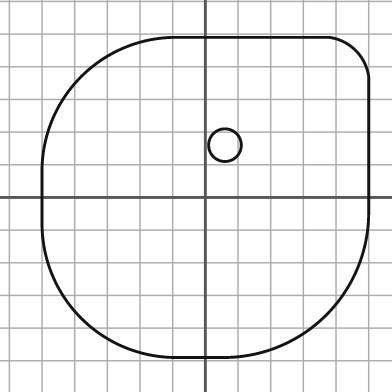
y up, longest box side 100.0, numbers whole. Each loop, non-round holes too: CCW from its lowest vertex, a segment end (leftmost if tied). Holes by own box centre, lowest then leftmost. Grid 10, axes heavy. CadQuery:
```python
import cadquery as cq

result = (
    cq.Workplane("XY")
    .moveTo(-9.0, -49.0)
    .lineTo(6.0, -49.0)
    .threePointArc((37.0, -36.0), (50.0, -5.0))
    .lineTo(50.0, 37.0)
    .threePointArc((46.0, 45.0), (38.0, 49.0))
    .lineTo(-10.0, 49.0)
    .threePointArc((-38.0, 37.0), (-50.0, 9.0))
    .lineTo(-50.0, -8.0)
    .threePointArc((-38.0, -37.0), (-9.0, -49.0))
    .close()
    .moveTo(6.0, 16.0)
    .circle(5.0)
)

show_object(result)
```